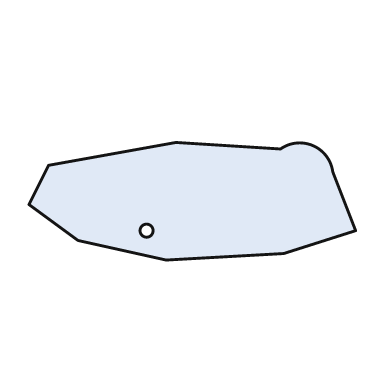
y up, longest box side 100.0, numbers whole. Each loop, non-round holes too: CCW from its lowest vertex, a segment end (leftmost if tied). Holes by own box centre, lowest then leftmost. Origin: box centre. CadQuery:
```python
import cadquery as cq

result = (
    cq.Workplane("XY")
    .moveTo(-8.0, -18.0)
    .lineTo(28.0, -16.0)
    .lineTo(50.0, -9.0)
    .lineTo(43.0, 9.0)
    .threePointArc((37.0, 17.0), (27.0, 16.0))
    .lineTo(-5.0, 18.0)
    .lineTo(-44.0, 11.0)
    .lineTo(-50.0, -1.0)
    .lineTo(-35.0, -12.0)
    .close()
    .moveTo(-14.0, -9.0)
    .circle(2.0)
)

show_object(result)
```